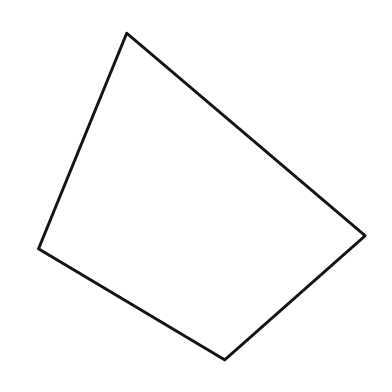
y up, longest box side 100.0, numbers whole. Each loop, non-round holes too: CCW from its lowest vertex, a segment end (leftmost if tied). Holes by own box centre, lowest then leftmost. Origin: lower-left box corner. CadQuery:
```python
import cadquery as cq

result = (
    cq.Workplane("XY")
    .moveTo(57.0, 0.0)
    .lineTo(100.0, 38.0)
    .lineTo(27.0, 100.0)
    .lineTo(0.0, 34.0)
    .close()
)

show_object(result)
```